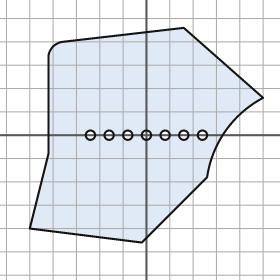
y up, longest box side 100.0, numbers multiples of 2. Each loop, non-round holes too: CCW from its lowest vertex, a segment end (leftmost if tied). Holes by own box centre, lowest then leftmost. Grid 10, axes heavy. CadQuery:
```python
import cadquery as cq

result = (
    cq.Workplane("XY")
    .moveTo(-2.0, -46.0)
    .lineTo(26.0, -18.0)
    .threePointArc((34.0, 2.0), (50.0, 16.0))
    .lineTo(16.0, 46.0)
    .lineTo(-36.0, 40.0)
    .threePointArc((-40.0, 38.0), (-42.0, 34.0))
    .lineTo(-42.0, -8.0)
    .lineTo(-50.0, -40.0)
    .close()
    .moveTo(-24.0, 0.0)
    .circle(2.0)
    .moveTo(-16.0, 0.0)
    .circle(2.0)
    .moveTo(-8.0, 0.0)
    .circle(2.0)
    .moveTo(0.0, 0.0)
    .circle(2.0)
    .moveTo(8.0, 0.0)
    .circle(2.0)
    .moveTo(16.0, 0.0)
    .circle(2.0)
    .moveTo(24.0, 0.0)
    .circle(2.0)
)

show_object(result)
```